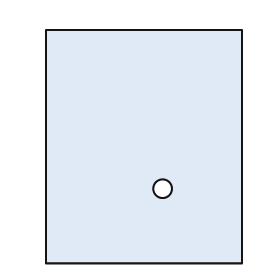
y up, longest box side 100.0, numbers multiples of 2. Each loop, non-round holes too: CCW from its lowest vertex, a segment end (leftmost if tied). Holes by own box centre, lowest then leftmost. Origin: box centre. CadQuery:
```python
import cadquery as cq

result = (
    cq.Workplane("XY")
    .moveTo(-42.0, -50.0)
    .lineTo(42.0, -50.0)
    .lineTo(42.0, 50.0)
    .lineTo(-42.0, 50.0)
    .close()
    .moveTo(8.0, -18.0)
    .circle(4.0)
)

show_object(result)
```